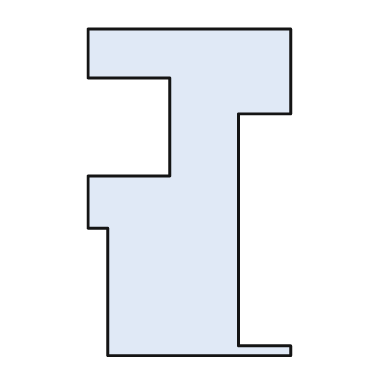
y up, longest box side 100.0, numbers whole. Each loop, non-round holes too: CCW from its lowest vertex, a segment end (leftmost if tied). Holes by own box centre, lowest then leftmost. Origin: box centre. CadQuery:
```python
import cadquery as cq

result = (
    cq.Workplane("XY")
    .moveTo(-25.0, -50.0)
    .lineTo(31.0, -50.0)
    .lineTo(31.0, -47.0)
    .lineTo(15.0, -47.0)
    .lineTo(15.0, 24.0)
    .lineTo(31.0, 24.0)
    .lineTo(31.0, 50.0)
    .lineTo(-31.0, 50.0)
    .lineTo(-31.0, 35.0)
    .lineTo(-6.0, 35.0)
    .lineTo(-6.0, 5.0)
    .lineTo(-31.0, 5.0)
    .lineTo(-31.0, -11.0)
    .lineTo(-25.0, -11.0)
    .close()
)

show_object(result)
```